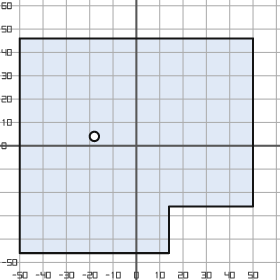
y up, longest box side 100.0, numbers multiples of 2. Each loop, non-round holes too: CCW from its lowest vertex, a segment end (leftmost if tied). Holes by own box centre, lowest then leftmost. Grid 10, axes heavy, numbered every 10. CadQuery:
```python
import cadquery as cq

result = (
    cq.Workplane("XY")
    .moveTo(-50.0, -46.0)
    .lineTo(14.0, -46.0)
    .lineTo(14.0, -26.0)
    .lineTo(50.0, -26.0)
    .lineTo(50.0, 46.0)
    .lineTo(-50.0, 46.0)
    .close()
    .moveTo(-18.0, 4.0)
    .circle(2.0)
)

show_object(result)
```